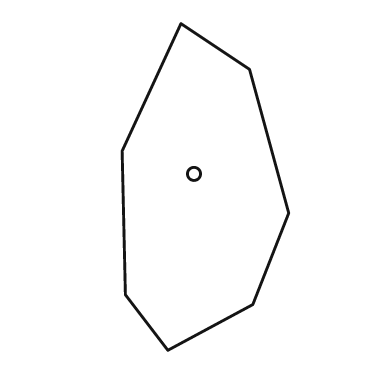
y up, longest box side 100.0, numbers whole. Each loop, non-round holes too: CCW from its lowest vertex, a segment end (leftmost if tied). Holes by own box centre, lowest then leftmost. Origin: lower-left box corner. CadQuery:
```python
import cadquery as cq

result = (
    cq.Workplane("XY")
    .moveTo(14.0, 0.0)
    .lineTo(40.0, 14.0)
    .lineTo(51.0, 42.0)
    .lineTo(39.0, 86.0)
    .lineTo(18.0, 100.0)
    .lineTo(0.0, 61.0)
    .lineTo(1.0, 17.0)
    .close()
    .moveTo(22.0, 54.0)
    .circle(2.0)
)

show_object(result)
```